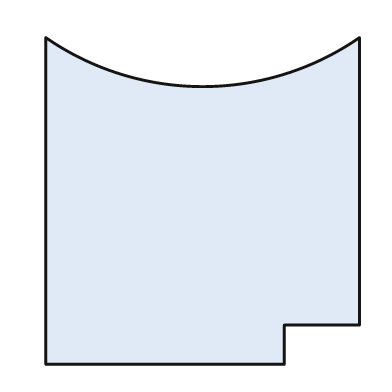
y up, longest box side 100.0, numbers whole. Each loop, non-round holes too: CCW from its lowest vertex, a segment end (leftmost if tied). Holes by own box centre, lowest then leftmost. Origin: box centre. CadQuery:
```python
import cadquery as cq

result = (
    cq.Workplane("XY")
    .moveTo(-48.0, -50.0)
    .lineTo(25.0, -50.0)
    .lineTo(25.0, -38.0)
    .lineTo(48.0, -38.0)
    .lineTo(48.0, 50.0)
    .threePointArc((0.0, 35.0), (-48.0, 50.0))
    .close()
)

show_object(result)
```